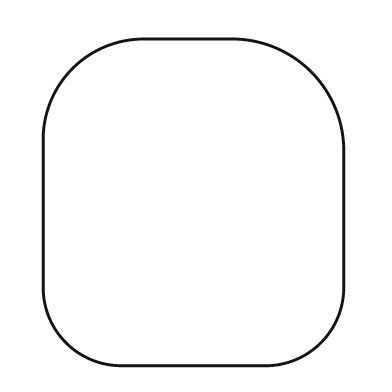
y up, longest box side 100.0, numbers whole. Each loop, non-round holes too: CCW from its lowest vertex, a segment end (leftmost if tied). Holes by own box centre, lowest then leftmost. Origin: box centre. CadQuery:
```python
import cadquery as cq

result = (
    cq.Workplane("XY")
    .moveTo(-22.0, -50.0)
    .lineTo(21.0, -50.0)
    .threePointArc((39.0, -43.0), (46.0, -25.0))
    .lineTo(46.0, 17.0)
    .threePointArc((36.0, 40.0), (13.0, 50.0))
    .lineTo(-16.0, 50.0)
    .threePointArc((-37.0, 41.0), (-46.0, 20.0))
    .lineTo(-46.0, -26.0)
    .threePointArc((-39.0, -43.0), (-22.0, -50.0))
    .close()
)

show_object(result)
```